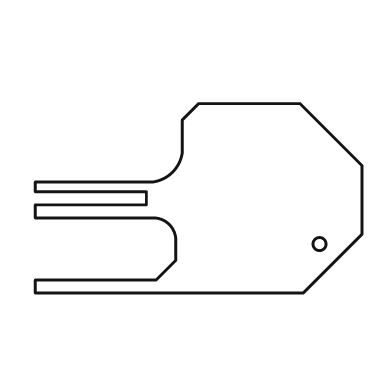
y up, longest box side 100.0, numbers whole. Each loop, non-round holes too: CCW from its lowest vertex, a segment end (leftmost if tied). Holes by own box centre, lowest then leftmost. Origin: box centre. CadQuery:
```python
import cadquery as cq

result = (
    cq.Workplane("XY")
    .moveTo(-50.0, -29.0)
    .lineTo(32.0, -29.0)
    .lineTo(50.0, -11.0)
    .lineTo(50.0, 10.0)
    .lineTo(31.0, 29.0)
    .lineTo(0.0, 29.0)
    .lineTo(-5.0, 24.0)
    .lineTo(-5.0, 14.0)
    .threePointArc((-8.0, 8.0), (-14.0, 5.0))
    .lineTo(-50.0, 5.0)
    .lineTo(-50.0, 2.0)
    .lineTo(-16.0, 2.0)
    .lineTo(-16.0, -2.0)
    .lineTo(-50.0, -2.0)
    .lineTo(-50.0, -6.0)
    .lineTo(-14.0, -6.0)
    .threePointArc((-9.0, -8.0), (-7.0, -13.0))
    .lineTo(-7.0, -19.0)
    .lineTo(-13.0, -25.0)
    .lineTo(-50.0, -25.0)
    .close()
    .moveTo(37.0, -14.0)
    .circle(2.0)
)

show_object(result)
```